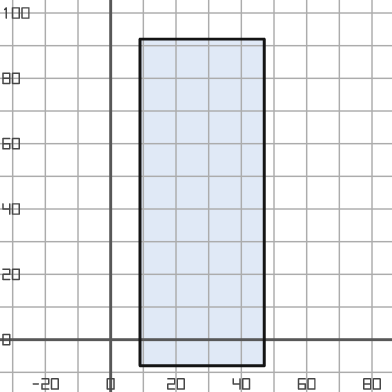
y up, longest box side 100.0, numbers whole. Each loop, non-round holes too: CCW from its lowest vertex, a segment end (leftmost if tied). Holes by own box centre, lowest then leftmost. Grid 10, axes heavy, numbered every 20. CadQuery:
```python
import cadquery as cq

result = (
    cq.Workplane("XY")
    .moveTo(9.0, -8.0)
    .lineTo(47.0, -8.0)
    .lineTo(47.0, 92.0)
    .lineTo(9.0, 92.0)
    .close()
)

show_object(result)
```